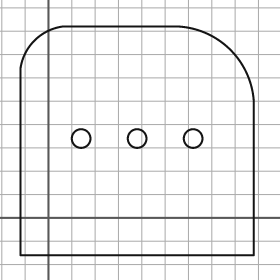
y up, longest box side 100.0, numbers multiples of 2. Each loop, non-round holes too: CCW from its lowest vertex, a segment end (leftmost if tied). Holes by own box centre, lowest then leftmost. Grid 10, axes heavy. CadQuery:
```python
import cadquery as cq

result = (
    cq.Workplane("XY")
    .moveTo(-12.0, -16.0)
    .lineTo(88.0, -16.0)
    .lineTo(88.0, 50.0)
    .threePointArc((78.0, 72.0), (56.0, 82.0))
    .lineTo(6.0, 82.0)
    .threePointArc((-6.0, 76.0), (-12.0, 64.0))
    .close()
    .moveTo(14.0, 34.0)
    .circle(4.0)
    .moveTo(38.0, 34.0)
    .circle(4.0)
    .moveTo(62.0, 34.0)
    .circle(4.0)
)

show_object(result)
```